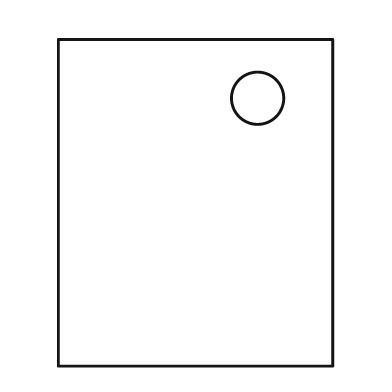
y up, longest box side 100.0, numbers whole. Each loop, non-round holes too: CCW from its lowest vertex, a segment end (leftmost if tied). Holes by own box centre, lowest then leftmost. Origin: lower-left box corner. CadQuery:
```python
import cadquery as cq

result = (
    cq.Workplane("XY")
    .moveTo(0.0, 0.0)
    .lineTo(84.0, 0.0)
    .lineTo(84.0, 100.0)
    .lineTo(0.0, 100.0)
    .close()
    .moveTo(61.0, 82.0)
    .circle(8.0)
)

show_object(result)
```